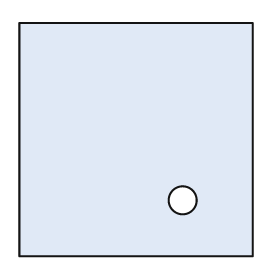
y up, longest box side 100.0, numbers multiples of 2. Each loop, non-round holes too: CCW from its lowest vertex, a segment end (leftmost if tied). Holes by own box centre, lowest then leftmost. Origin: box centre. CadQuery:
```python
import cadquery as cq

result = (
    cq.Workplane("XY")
    .moveTo(-50.0, -50.0)
    .lineTo(50.0, -50.0)
    .lineTo(50.0, 50.0)
    .lineTo(-50.0, 50.0)
    .close()
    .moveTo(20.0, -26.0)
    .circle(6.0)
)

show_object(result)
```